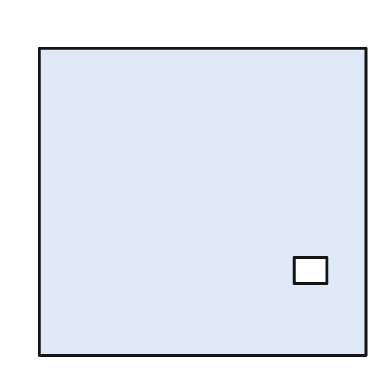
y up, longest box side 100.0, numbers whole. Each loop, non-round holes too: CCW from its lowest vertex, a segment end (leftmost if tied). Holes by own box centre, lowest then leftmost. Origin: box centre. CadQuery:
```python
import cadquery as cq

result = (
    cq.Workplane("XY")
    .moveTo(-50.0, -47.0)
    .lineTo(50.0, -47.0)
    .lineTo(50.0, 47.0)
    .lineTo(-50.0, 47.0)
    .close()
    .moveTo(28.0, -25.0)
    .lineTo(38.0, -25.0)
    .lineTo(38.0, -17.0)
    .lineTo(28.0, -17.0)
    .close()
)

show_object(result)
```